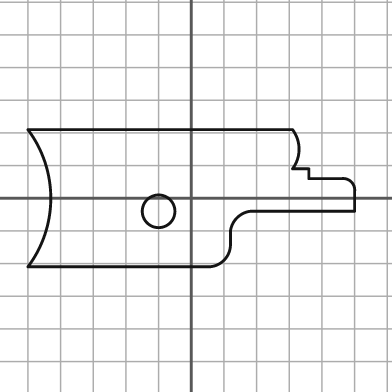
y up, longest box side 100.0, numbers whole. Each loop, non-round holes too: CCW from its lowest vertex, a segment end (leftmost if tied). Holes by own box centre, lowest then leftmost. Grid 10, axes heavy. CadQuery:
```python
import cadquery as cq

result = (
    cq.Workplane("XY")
    .moveTo(-50.0, -21.0)
    .lineTo(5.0, -21.0)
    .threePointArc((10.0, -19.0), (12.0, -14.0))
    .lineTo(12.0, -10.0)
    .threePointArc((14.0, -6.0), (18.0, -4.0))
    .lineTo(50.0, -4.0)
    .lineTo(50.0, 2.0)
    .threePointArc((49.0, 5.0), (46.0, 6.0))
    .lineTo(36.0, 6.0)
    .lineTo(36.0, 9.0)
    .lineTo(31.0, 9.0)
    .threePointArc((33.0, 15.0), (31.0, 21.0))
    .lineTo(-50.0, 21.0)
    .threePointArc((-43.0, 0.0), (-50.0, -21.0))
    .close()
    .moveTo(-10.0, -4.0)
    .circle(5.0)
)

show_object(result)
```